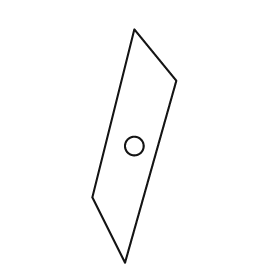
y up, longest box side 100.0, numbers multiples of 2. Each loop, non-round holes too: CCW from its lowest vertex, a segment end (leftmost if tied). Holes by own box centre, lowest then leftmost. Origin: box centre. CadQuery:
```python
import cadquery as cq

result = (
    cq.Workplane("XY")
    .moveTo(-4.0, -50.0)
    .lineTo(18.0, 28.0)
    .lineTo(0.0, 50.0)
    .lineTo(-18.0, -22.0)
    .close()
    .moveTo(0.0, 0.0)
    .circle(4.0)
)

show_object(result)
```